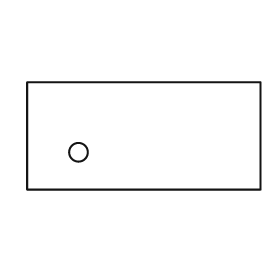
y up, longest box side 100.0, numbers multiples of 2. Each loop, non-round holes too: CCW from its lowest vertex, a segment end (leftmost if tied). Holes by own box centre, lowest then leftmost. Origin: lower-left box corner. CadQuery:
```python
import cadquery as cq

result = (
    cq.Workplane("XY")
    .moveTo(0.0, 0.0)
    .lineTo(100.0, 0.0)
    .lineTo(100.0, 46.0)
    .lineTo(0.0, 46.0)
    .close()
    .moveTo(22.0, 16.0)
    .circle(4.0)
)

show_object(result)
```